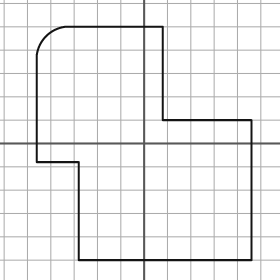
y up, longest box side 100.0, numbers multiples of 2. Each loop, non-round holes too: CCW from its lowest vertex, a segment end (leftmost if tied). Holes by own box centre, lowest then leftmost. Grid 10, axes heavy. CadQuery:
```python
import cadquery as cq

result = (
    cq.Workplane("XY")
    .moveTo(-28.0, -50.0)
    .lineTo(46.0, -50.0)
    .lineTo(46.0, 10.0)
    .lineTo(8.0, 10.0)
    .lineTo(8.0, 50.0)
    .lineTo(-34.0, 50.0)
    .threePointArc((-42.0, 46.0), (-46.0, 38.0))
    .lineTo(-46.0, -8.0)
    .lineTo(-28.0, -8.0)
    .close()
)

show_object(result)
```